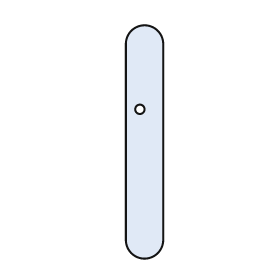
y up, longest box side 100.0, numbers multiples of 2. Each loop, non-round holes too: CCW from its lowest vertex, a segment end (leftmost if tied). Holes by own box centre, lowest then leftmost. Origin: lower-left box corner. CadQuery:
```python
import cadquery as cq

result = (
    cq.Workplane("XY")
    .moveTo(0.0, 8.0)
    .threePointArc((8.0, 0.0), (16.0, 8.0))
    .lineTo(16.0, 92.0)
    .threePointArc((8.0, 100.0), (0.0, 92.0))
    .close()
    .moveTo(6.0, 64.0)
    .circle(2.0)
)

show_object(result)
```